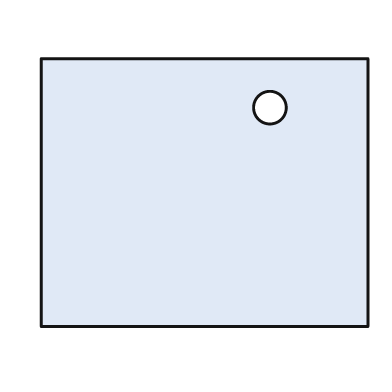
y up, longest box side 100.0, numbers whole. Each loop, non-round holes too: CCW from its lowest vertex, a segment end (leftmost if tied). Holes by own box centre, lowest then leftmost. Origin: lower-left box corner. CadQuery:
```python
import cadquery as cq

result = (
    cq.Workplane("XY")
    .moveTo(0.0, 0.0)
    .lineTo(100.0, 0.0)
    .lineTo(100.0, 82.0)
    .lineTo(0.0, 82.0)
    .close()
    .moveTo(70.0, 67.0)
    .circle(5.0)
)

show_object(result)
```